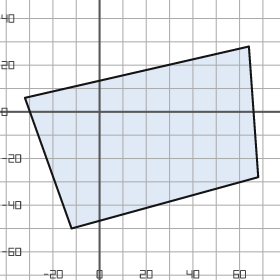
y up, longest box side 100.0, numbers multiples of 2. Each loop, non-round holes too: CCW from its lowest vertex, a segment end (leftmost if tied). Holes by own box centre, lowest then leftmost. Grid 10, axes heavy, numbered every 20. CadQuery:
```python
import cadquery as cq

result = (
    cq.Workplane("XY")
    .moveTo(-12.0, -50.0)
    .lineTo(68.0, -28.0)
    .lineTo(64.0, 28.0)
    .lineTo(-32.0, 6.0)
    .close()
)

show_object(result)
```